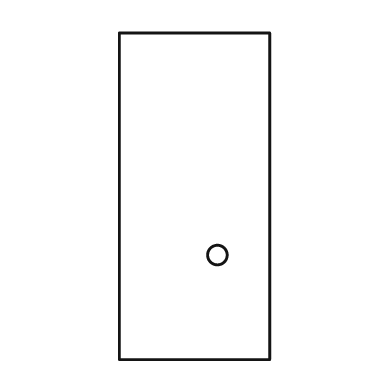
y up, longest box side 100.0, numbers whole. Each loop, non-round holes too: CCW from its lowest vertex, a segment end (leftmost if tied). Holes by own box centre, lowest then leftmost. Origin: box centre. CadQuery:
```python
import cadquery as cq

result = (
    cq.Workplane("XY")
    .moveTo(-23.0, -50.0)
    .lineTo(23.0, -50.0)
    .lineTo(23.0, 50.0)
    .lineTo(-23.0, 50.0)
    .close()
    .moveTo(7.0, -18.0)
    .circle(3.0)
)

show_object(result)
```